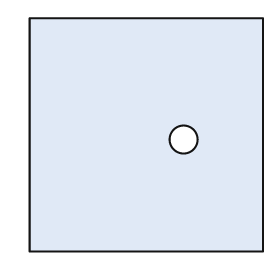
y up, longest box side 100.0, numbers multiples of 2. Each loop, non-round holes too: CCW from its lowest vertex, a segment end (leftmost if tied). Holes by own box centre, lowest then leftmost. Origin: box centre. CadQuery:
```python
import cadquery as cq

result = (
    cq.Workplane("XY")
    .moveTo(-50.0, -50.0)
    .lineTo(50.0, -50.0)
    .lineTo(50.0, 50.0)
    .lineTo(-50.0, 50.0)
    .close()
    .moveTo(16.0, -2.0)
    .circle(6.0)
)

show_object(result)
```